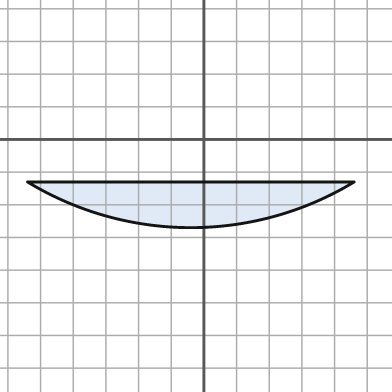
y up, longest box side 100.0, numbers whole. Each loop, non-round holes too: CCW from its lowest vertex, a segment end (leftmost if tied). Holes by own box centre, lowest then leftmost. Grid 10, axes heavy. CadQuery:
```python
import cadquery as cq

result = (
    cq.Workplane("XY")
    .moveTo(-54.0, -13.0)
    .threePointArc((-4.0, -27.0), (46.0, -13.0))
    .close()
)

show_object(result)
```